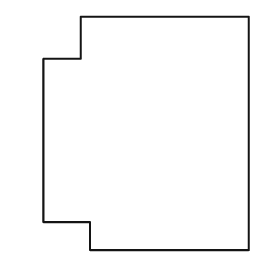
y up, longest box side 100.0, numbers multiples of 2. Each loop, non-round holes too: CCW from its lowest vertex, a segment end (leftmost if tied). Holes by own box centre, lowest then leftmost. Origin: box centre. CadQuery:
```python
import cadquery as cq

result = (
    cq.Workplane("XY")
    .moveTo(-24.0, -50.0)
    .lineTo(44.0, -50.0)
    .lineTo(44.0, 50.0)
    .lineTo(-28.0, 50.0)
    .lineTo(-28.0, 32.0)
    .lineTo(-44.0, 32.0)
    .lineTo(-44.0, -38.0)
    .lineTo(-24.0, -38.0)
    .close()
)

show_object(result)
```